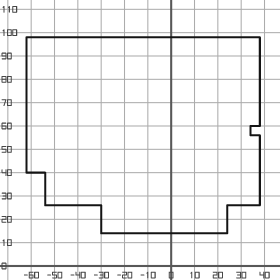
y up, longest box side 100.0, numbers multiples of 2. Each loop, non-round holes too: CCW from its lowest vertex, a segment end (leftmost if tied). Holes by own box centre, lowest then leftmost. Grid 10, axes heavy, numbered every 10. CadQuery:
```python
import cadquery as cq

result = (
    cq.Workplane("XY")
    .moveTo(-30.0, 14.0)
    .lineTo(24.0, 14.0)
    .lineTo(24.0, 26.0)
    .lineTo(38.0, 26.0)
    .lineTo(38.0, 56.0)
    .lineTo(34.0, 56.0)
    .lineTo(34.0, 60.0)
    .lineTo(38.0, 60.0)
    .lineTo(38.0, 98.0)
    .lineTo(-62.0, 98.0)
    .lineTo(-62.0, 40.0)
    .lineTo(-54.0, 40.0)
    .lineTo(-54.0, 26.0)
    .lineTo(-30.0, 26.0)
    .close()
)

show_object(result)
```